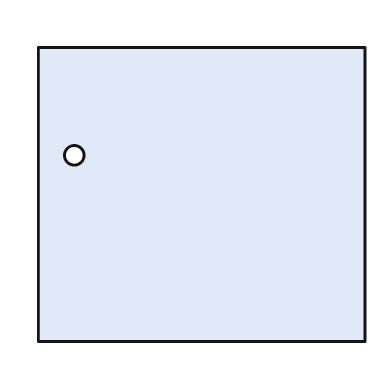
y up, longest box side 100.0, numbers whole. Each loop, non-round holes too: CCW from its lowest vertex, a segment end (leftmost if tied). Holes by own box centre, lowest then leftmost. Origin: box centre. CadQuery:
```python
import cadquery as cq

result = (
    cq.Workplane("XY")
    .moveTo(-50.0, -45.0)
    .lineTo(50.0, -45.0)
    .lineTo(50.0, 45.0)
    .lineTo(-50.0, 45.0)
    .close()
    .moveTo(-39.0, 12.0)
    .circle(3.0)
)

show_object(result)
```